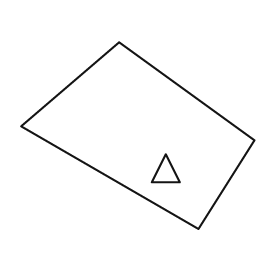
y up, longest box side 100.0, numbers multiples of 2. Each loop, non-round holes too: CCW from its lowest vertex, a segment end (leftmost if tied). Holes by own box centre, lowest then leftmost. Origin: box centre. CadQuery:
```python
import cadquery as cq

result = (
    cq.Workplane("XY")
    .moveTo(26.0, -40.0)
    .lineTo(50.0, -2.0)
    .lineTo(-8.0, 40.0)
    .lineTo(-50.0, 4.0)
    .close()
    .moveTo(6.0, -20.0)
    .lineTo(18.0, -20.0)
    .lineTo(12.0, -8.0)
    .close()
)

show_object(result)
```